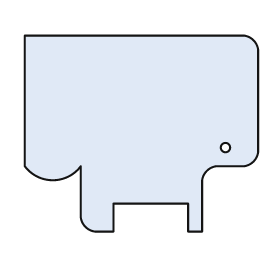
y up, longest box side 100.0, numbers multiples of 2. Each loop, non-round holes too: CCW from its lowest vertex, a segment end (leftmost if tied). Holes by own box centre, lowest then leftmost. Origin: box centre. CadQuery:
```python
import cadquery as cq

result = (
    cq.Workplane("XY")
    .moveTo(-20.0, -42.0)
    .lineTo(-12.0, -42.0)
    .lineTo(-12.0, -30.0)
    .lineTo(20.0, -30.0)
    .lineTo(20.0, -42.0)
    .lineTo(26.0, -42.0)
    .lineTo(26.0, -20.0)
    .threePointArc((28.0, -16.0), (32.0, -14.0))
    .lineTo(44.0, -14.0)
    .threePointArc((48.0, -12.0), (50.0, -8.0))
    .lineTo(50.0, 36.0)
    .threePointArc((48.0, 40.0), (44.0, 42.0))
    .lineTo(-50.0, 42.0)
    .lineTo(-50.0, -14.0)
    .threePointArc((-38.0, -20.0), (-26.0, -14.0))
    .lineTo(-26.0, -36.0)
    .threePointArc((-24.0, -40.0), (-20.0, -42.0))
    .close()
    .moveTo(36.0, -6.0)
    .circle(2.0)
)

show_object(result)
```